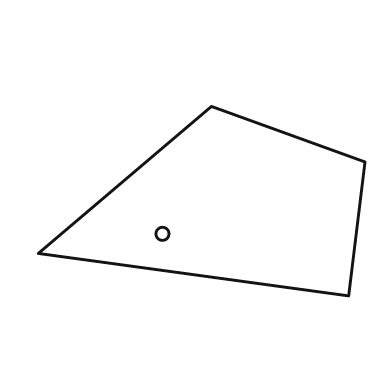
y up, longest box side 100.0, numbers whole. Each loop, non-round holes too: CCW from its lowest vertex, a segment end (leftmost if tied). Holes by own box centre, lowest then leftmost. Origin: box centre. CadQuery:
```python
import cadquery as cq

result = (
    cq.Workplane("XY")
    .moveTo(45.0, -29.0)
    .lineTo(50.0, 12.0)
    .lineTo(3.0, 29.0)
    .lineTo(-50.0, -16.0)
    .close()
    .moveTo(-12.0, -10.0)
    .circle(2.0)
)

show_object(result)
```